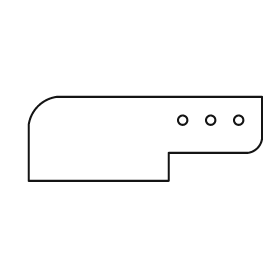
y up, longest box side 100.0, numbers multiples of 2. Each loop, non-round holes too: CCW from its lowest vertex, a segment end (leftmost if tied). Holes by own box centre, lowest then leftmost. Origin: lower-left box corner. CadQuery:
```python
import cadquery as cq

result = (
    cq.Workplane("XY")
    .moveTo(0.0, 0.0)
    .lineTo(60.0, 0.0)
    .lineTo(60.0, 12.0)
    .lineTo(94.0, 12.0)
    .threePointArc((98.0, 14.0), (100.0, 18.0))
    .lineTo(100.0, 36.0)
    .lineTo(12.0, 36.0)
    .threePointArc((4.0, 32.0), (0.0, 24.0))
    .close()
    .moveTo(66.0, 26.0)
    .circle(2.0)
    .moveTo(78.0, 26.0)
    .circle(2.0)
    .moveTo(90.0, 26.0)
    .circle(2.0)
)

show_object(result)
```